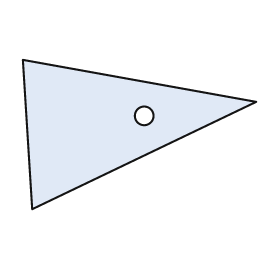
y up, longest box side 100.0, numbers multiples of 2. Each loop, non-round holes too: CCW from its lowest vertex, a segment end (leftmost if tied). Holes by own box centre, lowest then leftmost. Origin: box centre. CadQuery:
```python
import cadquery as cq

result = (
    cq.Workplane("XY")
    .moveTo(-46.0, -32.0)
    .lineTo(50.0, 14.0)
    .lineTo(-50.0, 32.0)
    .close()
    .moveTo(2.0, 8.0)
    .circle(4.0)
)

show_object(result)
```